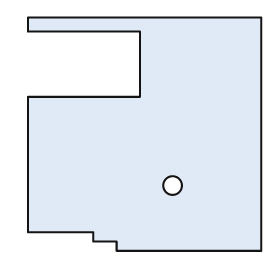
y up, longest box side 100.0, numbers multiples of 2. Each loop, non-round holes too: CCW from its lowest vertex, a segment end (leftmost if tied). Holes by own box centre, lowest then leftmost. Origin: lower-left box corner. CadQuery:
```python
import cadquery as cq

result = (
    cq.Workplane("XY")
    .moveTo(38.0, 0.0)
    .lineTo(100.0, 0.0)
    .lineTo(100.0, 100.0)
    .lineTo(0.0, 100.0)
    .lineTo(0.0, 94.0)
    .lineTo(48.0, 94.0)
    .lineTo(48.0, 66.0)
    .lineTo(0.0, 66.0)
    .lineTo(0.0, 8.0)
    .lineTo(28.0, 8.0)
    .lineTo(28.0, 4.0)
    .lineTo(38.0, 4.0)
    .close()
    .moveTo(62.0, 28.0)
    .circle(4.0)
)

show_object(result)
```